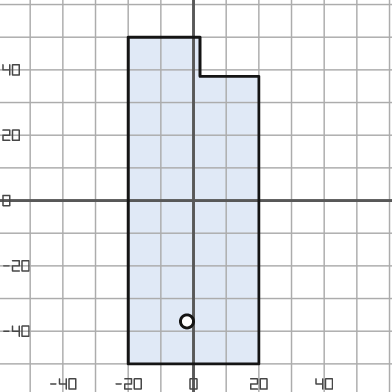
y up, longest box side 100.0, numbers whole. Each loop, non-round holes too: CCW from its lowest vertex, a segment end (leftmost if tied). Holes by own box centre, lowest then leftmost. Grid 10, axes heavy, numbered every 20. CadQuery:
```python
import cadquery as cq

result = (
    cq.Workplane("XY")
    .moveTo(-20.0, -50.0)
    .lineTo(20.0, -50.0)
    .lineTo(20.0, 38.0)
    .lineTo(2.0, 38.0)
    .lineTo(2.0, 50.0)
    .lineTo(-20.0, 50.0)
    .close()
    .moveTo(-2.0, -37.0)
    .circle(2.0)
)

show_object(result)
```